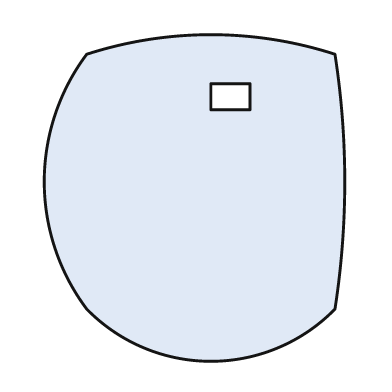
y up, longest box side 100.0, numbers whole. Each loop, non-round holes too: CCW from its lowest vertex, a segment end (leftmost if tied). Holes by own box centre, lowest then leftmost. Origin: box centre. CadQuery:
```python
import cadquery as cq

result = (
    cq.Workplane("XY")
    .moveTo(-33.0, -34.0)
    .threePointArc((5.0, -50.0), (43.0, -34.0))
    .threePointArc((46.0, 5.0), (43.0, 44.0))
    .threePointArc((5.0, 50.0), (-33.0, 44.0))
    .threePointArc((-46.0, 5.0), (-33.0, -34.0))
    .close()
    .moveTo(5.0, 27.0)
    .lineTo(17.0, 27.0)
    .lineTo(17.0, 35.0)
    .lineTo(5.0, 35.0)
    .close()
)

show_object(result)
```